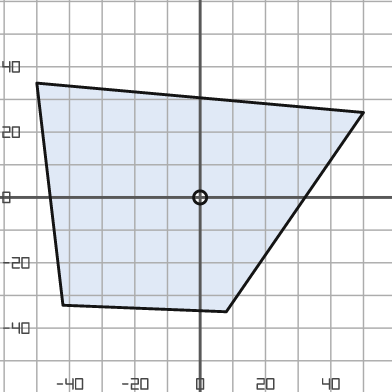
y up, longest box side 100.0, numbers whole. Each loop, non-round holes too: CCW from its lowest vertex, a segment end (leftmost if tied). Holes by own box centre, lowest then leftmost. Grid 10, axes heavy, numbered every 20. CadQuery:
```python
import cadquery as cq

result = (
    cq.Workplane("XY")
    .moveTo(8.0, -35.0)
    .lineTo(50.0, 26.0)
    .lineTo(-50.0, 35.0)
    .lineTo(-42.0, -33.0)
    .close()
    .moveTo(0.0, 0.0)
    .circle(2.0)
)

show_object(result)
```